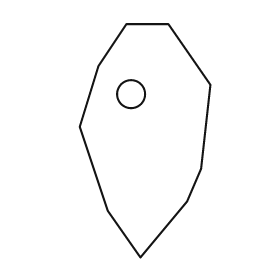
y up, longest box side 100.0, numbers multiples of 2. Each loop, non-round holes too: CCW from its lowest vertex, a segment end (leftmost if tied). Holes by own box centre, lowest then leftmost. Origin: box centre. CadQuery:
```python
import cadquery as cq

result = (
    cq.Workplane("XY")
    .moveTo(-2.0, -50.0)
    .lineTo(18.0, -26.0)
    .lineTo(24.0, -12.0)
    .lineTo(28.0, 24.0)
    .lineTo(10.0, 50.0)
    .lineTo(-8.0, 50.0)
    .lineTo(-20.0, 32.0)
    .lineTo(-28.0, 6.0)
    .lineTo(-16.0, -30.0)
    .close()
    .moveTo(-6.0, 20.0)
    .circle(6.0)
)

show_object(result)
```